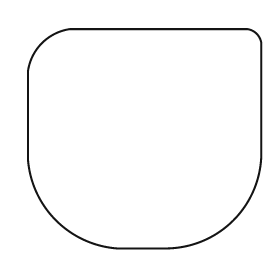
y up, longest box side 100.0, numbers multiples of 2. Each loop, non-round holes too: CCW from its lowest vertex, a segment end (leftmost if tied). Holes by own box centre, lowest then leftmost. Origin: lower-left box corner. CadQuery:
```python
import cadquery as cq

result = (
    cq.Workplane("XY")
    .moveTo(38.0, 0.0)
    .lineTo(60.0, 0.0)
    .threePointArc((88.0, 12.0), (100.0, 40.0))
    .lineTo(100.0, 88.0)
    .threePointArc((98.0, 92.0), (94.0, 94.0))
    .lineTo(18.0, 94.0)
    .threePointArc((6.0, 88.0), (0.0, 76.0))
    .lineTo(0.0, 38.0)
    .threePointArc((12.0, 12.0), (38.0, 0.0))
    .close()
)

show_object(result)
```